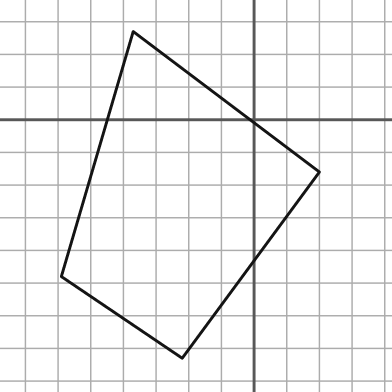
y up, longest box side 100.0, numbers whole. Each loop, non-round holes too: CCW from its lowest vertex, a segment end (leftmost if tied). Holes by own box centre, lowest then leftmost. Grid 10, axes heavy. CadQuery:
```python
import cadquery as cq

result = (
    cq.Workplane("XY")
    .moveTo(-22.0, -73.0)
    .lineTo(20.0, -16.0)
    .lineTo(-37.0, 27.0)
    .lineTo(-59.0, -48.0)
    .close()
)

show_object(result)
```